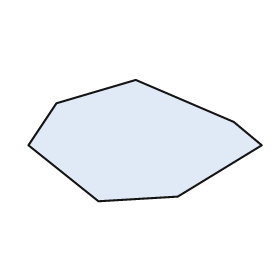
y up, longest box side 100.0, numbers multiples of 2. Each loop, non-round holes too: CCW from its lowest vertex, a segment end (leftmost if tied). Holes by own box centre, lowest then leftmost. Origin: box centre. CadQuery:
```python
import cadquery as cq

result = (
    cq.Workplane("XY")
    .moveTo(-20.0, -26.0)
    .lineTo(14.0, -24.0)
    .lineTo(50.0, -2.0)
    .lineTo(38.0, 8.0)
    .lineTo(-4.0, 26.0)
    .lineTo(-38.0, 16.0)
    .lineTo(-50.0, -2.0)
    .close()
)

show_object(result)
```